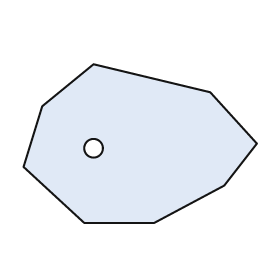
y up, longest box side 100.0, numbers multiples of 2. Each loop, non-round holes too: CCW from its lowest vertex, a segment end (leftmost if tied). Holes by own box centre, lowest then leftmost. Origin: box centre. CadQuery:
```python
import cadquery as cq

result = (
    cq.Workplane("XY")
    .moveTo(-24.0, -34.0)
    .lineTo(6.0, -34.0)
    .lineTo(36.0, -18.0)
    .lineTo(50.0, 0.0)
    .lineTo(30.0, 22.0)
    .lineTo(-20.0, 34.0)
    .lineTo(-42.0, 16.0)
    .lineTo(-50.0, -10.0)
    .close()
    .moveTo(-20.0, -2.0)
    .circle(4.0)
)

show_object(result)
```